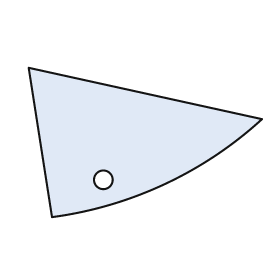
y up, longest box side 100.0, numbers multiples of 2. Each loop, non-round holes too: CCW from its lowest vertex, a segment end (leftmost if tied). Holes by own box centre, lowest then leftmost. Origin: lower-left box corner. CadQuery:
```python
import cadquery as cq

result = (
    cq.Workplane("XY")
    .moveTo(10.0, 0.0)
    .threePointArc((58.0, 14.0), (100.0, 42.0))
    .lineTo(0.0, 64.0)
    .close()
    .moveTo(32.0, 16.0)
    .circle(4.0)
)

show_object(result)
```